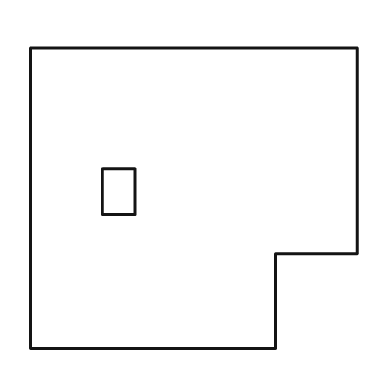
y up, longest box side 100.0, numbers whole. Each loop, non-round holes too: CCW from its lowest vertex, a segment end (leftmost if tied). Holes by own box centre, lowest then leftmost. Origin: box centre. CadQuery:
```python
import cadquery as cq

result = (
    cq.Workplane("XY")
    .moveTo(-50.0, -46.0)
    .lineTo(25.0, -46.0)
    .lineTo(25.0, -17.0)
    .lineTo(50.0, -17.0)
    .lineTo(50.0, 46.0)
    .lineTo(-50.0, 46.0)
    .close()
    .moveTo(-28.0, -5.0)
    .lineTo(-18.0, -5.0)
    .lineTo(-18.0, 9.0)
    .lineTo(-28.0, 9.0)
    .close()
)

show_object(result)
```